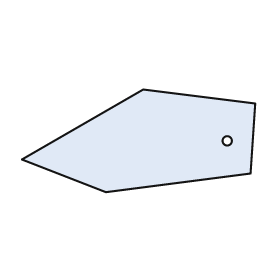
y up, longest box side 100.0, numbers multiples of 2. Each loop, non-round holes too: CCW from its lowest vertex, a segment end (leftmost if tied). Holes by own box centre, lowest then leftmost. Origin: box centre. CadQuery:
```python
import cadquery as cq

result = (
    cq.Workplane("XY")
    .moveTo(-14.0, -22.0)
    .lineTo(48.0, -14.0)
    .lineTo(50.0, 16.0)
    .lineTo(2.0, 22.0)
    .lineTo(-50.0, -8.0)
    .close()
    .moveTo(38.0, 0.0)
    .circle(2.0)
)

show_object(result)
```